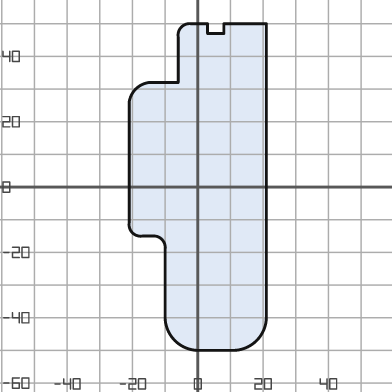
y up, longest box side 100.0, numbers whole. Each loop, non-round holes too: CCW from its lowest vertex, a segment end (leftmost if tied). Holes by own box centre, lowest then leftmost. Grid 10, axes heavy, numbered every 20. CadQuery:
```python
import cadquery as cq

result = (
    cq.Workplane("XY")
    .moveTo(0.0, -50.0)
    .lineTo(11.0, -50.0)
    .threePointArc((18.0, -47.0), (21.0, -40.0))
    .lineTo(21.0, 50.0)
    .lineTo(8.0, 50.0)
    .lineTo(8.0, 47.0)
    .lineTo(3.0, 47.0)
    .lineTo(3.0, 50.0)
    .lineTo(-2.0, 50.0)
    .threePointArc((-5.0, 49.0), (-6.0, 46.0))
    .lineTo(-6.0, 32.0)
    .lineTo(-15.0, 32.0)
    .threePointArc((-19.0, 30.0), (-21.0, 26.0))
    .lineTo(-21.0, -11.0)
    .threePointArc((-20.0, -14.0), (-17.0, -15.0))
    .lineTo(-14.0, -15.0)
    .threePointArc((-11.0, -16.0), (-10.0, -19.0))
    .lineTo(-10.0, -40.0)
    .threePointArc((-7.0, -47.0), (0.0, -50.0))
    .close()
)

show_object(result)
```